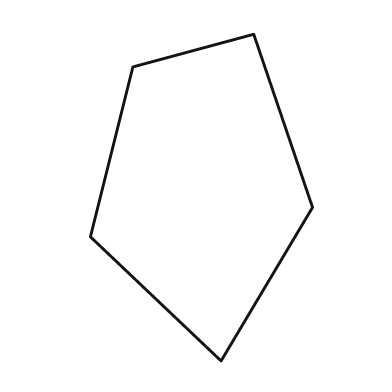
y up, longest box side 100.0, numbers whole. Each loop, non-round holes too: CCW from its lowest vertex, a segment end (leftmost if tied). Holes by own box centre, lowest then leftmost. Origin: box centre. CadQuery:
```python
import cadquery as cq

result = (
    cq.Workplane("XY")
    .moveTo(6.0, -50.0)
    .lineTo(34.0, -3.0)
    .lineTo(16.0, 50.0)
    .lineTo(-21.0, 40.0)
    .lineTo(-34.0, -12.0)
    .close()
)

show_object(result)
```